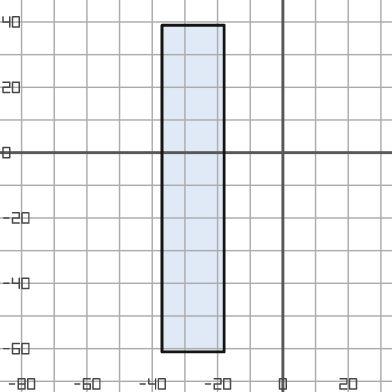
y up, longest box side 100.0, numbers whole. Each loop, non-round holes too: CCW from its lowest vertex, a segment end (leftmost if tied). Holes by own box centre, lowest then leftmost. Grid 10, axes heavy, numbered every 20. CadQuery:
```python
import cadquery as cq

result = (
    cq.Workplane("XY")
    .moveTo(-37.0, -61.0)
    .lineTo(-18.0, -61.0)
    .lineTo(-18.0, 39.0)
    .lineTo(-37.0, 39.0)
    .close()
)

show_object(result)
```